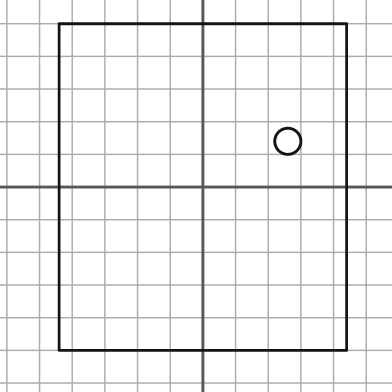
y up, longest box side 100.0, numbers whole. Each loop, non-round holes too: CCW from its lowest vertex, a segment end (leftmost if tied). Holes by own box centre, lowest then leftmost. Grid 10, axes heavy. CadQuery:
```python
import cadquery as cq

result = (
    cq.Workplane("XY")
    .moveTo(-44.0, -50.0)
    .lineTo(44.0, -50.0)
    .lineTo(44.0, 50.0)
    .lineTo(-44.0, 50.0)
    .close()
    .moveTo(26.0, 14.0)
    .circle(4.0)
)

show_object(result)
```